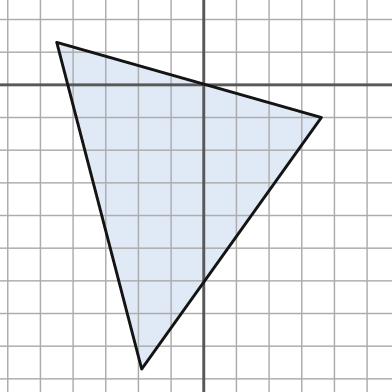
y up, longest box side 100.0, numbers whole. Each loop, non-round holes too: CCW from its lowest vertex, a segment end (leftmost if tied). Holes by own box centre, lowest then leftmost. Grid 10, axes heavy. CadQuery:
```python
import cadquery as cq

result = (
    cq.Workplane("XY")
    .moveTo(-19.0, -87.0)
    .lineTo(36.0, -10.0)
    .lineTo(-45.0, 13.0)
    .close()
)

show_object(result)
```